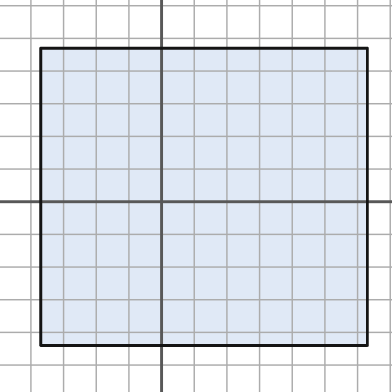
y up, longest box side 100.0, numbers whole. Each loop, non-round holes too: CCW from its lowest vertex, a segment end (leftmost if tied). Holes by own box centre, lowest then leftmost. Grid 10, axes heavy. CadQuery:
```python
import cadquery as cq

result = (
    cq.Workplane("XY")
    .moveTo(-37.0, -44.0)
    .lineTo(63.0, -44.0)
    .lineTo(63.0, 47.0)
    .lineTo(-37.0, 47.0)
    .close()
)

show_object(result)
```